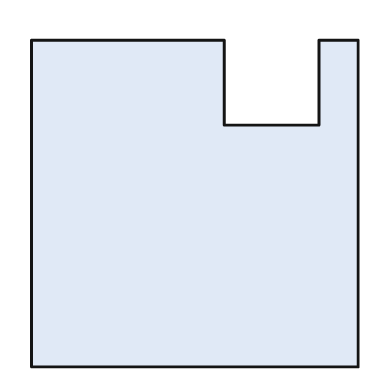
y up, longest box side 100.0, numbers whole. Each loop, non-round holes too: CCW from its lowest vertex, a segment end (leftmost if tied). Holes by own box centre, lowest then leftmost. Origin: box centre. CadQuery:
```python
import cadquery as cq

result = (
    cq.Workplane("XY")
    .moveTo(-50.0, -50.0)
    .lineTo(50.0, -50.0)
    .lineTo(50.0, 50.0)
    .lineTo(38.0, 50.0)
    .lineTo(38.0, 24.0)
    .lineTo(9.0, 24.0)
    .lineTo(9.0, 50.0)
    .lineTo(-50.0, 50.0)
    .close()
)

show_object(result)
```